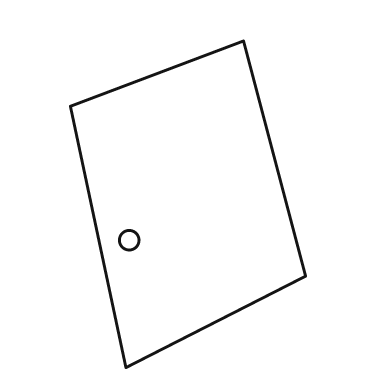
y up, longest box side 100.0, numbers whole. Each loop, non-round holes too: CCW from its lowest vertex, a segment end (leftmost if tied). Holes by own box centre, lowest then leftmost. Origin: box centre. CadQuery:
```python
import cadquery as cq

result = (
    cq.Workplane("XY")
    .moveTo(-19.0, -50.0)
    .lineTo(36.0, -22.0)
    .lineTo(17.0, 50.0)
    .lineTo(-36.0, 30.0)
    .close()
    .moveTo(-18.0, -11.0)
    .circle(3.0)
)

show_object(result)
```